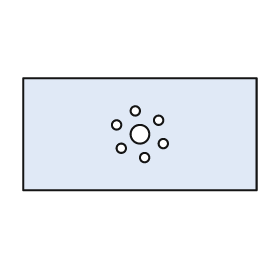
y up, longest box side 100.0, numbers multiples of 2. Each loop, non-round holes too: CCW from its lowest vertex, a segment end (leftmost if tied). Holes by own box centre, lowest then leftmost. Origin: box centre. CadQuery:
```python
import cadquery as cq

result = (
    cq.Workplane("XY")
    .moveTo(-50.0, -24.0)
    .lineTo(50.0, -24.0)
    .lineTo(50.0, 24.0)
    .lineTo(-50.0, 24.0)
    .close()
    .moveTo(2.0, -10.0)
    .circle(2.0)
    .moveTo(-8.0, -6.0)
    .circle(2.0)
    .moveTo(10.0, -4.0)
    .circle(2.0)
    .moveTo(0.0, 0.0)
    .circle(4.0)
    .moveTo(-10.0, 4.0)
    .circle(2.0)
    .moveTo(8.0, 6.0)
    .circle(2.0)
    .moveTo(-2.0, 10.0)
    .circle(2.0)
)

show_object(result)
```